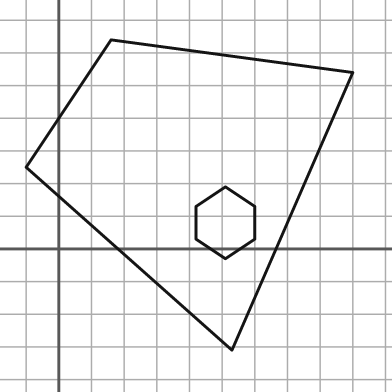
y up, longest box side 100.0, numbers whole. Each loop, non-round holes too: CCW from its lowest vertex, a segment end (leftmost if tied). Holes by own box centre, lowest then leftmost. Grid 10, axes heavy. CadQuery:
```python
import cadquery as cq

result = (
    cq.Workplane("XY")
    .moveTo(53.0, -31.0)
    .lineTo(90.0, 54.0)
    .lineTo(16.0, 64.0)
    .lineTo(-10.0, 25.0)
    .close()
    .moveTo(51.0, -3.0)
    .lineTo(60.0, 3.0)
    .lineTo(60.0, 13.0)
    .lineTo(51.0, 19.0)
    .lineTo(42.0, 13.0)
    .lineTo(42.0, 3.0)
    .close()
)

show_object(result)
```